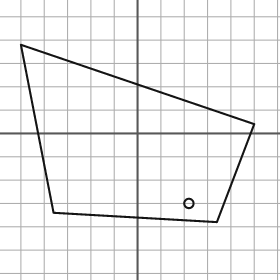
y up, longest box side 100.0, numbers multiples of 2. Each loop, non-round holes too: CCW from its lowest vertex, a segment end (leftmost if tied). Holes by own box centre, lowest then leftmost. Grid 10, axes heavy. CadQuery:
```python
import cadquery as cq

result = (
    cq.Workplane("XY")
    .moveTo(34.0, -38.0)
    .lineTo(50.0, 4.0)
    .lineTo(-50.0, 38.0)
    .lineTo(-36.0, -34.0)
    .close()
    .moveTo(22.0, -30.0)
    .circle(2.0)
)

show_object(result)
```